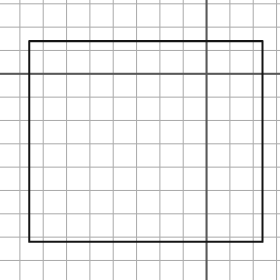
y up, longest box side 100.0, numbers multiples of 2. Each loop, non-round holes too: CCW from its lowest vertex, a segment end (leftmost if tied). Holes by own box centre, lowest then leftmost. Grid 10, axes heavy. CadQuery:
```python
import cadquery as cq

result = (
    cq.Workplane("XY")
    .moveTo(-76.0, -72.0)
    .lineTo(24.0, -72.0)
    .lineTo(24.0, 14.0)
    .lineTo(-76.0, 14.0)
    .close()
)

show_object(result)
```